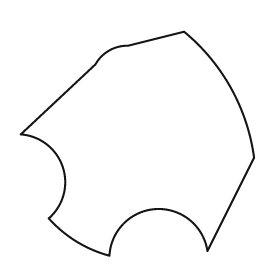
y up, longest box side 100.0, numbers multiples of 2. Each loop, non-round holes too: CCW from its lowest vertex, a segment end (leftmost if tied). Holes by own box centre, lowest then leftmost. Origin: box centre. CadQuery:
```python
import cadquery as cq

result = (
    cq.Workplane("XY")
    .moveTo(-12.0, -48.0)
    .threePointArc((8.0, -28.0), (30.0, -46.0))
    .lineTo(50.0, -6.0)
    .threePointArc((40.0, 24.0), (20.0, 48.0))
    .lineTo(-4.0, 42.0)
    .threePointArc((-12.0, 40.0), (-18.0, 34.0))
    .lineTo(-50.0, 4.0)
    .threePointArc((-32.0, -10.0), (-38.0, -32.0))
    .threePointArc((-26.0, -42.0), (-12.0, -48.0))
    .close()
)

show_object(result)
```